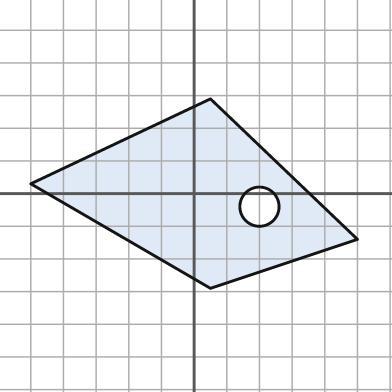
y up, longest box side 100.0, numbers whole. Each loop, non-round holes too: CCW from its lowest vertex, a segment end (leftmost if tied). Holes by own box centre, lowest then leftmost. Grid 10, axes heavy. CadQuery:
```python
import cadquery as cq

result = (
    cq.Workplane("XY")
    .moveTo(5.0, -29.0)
    .lineTo(50.0, -14.0)
    .lineTo(5.0, 29.0)
    .lineTo(-50.0, 3.0)
    .close()
    .moveTo(20.0, -4.0)
    .circle(6.0)
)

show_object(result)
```